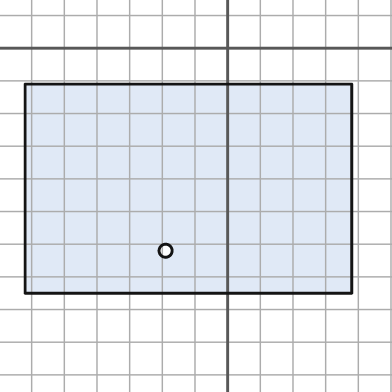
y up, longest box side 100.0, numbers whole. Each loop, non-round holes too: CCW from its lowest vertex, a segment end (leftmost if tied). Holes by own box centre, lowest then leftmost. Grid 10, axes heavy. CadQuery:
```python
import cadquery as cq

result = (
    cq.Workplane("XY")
    .moveTo(-62.0, -75.0)
    .lineTo(38.0, -75.0)
    .lineTo(38.0, -11.0)
    .lineTo(-62.0, -11.0)
    .close()
    .moveTo(-19.0, -62.0)
    .circle(2.0)
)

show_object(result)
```